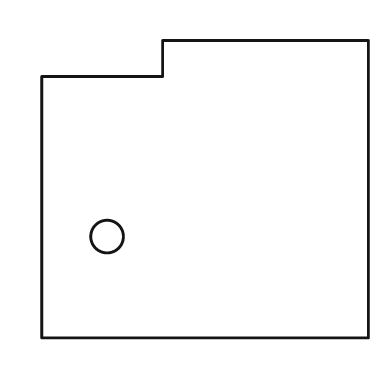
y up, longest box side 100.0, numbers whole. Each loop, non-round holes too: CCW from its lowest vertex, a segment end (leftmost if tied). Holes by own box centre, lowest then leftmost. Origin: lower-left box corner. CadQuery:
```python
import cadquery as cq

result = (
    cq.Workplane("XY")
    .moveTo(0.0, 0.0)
    .lineTo(100.0, 0.0)
    .lineTo(100.0, 91.0)
    .lineTo(37.0, 91.0)
    .lineTo(37.0, 80.0)
    .lineTo(0.0, 80.0)
    .close()
    .moveTo(20.0, 31.0)
    .circle(5.0)
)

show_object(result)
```